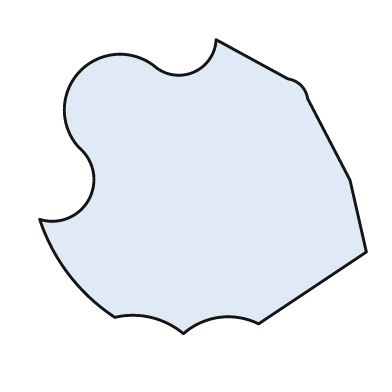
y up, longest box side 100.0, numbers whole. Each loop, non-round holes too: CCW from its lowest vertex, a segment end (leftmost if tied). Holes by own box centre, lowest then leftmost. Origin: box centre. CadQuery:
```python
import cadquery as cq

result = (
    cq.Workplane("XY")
    .moveTo(-6.0, -45.0)
    .threePointArc((5.0, -40.0), (17.0, -42.0))
    .lineTo(50.0, -20.0)
    .lineTo(45.0, 2.0)
    .lineTo(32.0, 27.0)
    .threePointArc((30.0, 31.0), (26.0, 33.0))
    .lineTo(4.0, 45.0)
    .threePointArc((-3.0, 35.0), (-15.0, 37.0))
    .threePointArc((-38.0, 35.0), (-38.0, 12.0))
    .threePointArc((-35.0, -4.0), (-50.0, -10.0))
    .threePointArc((-41.0, -27.0), (-27.0, -40.0))
    .threePointArc((-16.0, -40.0), (-6.0, -45.0))
    .close()
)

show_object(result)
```